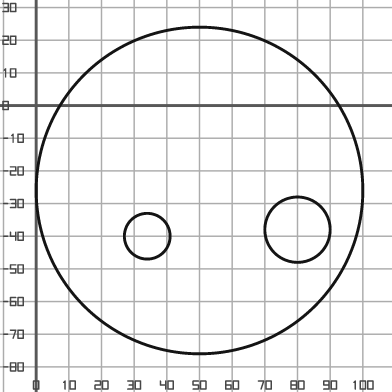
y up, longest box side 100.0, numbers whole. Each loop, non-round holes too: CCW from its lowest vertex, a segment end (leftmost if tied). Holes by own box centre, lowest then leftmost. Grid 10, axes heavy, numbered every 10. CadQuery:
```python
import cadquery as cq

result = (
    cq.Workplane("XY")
    .moveTo(50.0, -26.0)
    .circle(50.0)
    .moveTo(34.0, -40.0)
    .circle(7.0)
    .moveTo(80.0, -38.0)
    .circle(10.0)
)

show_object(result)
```